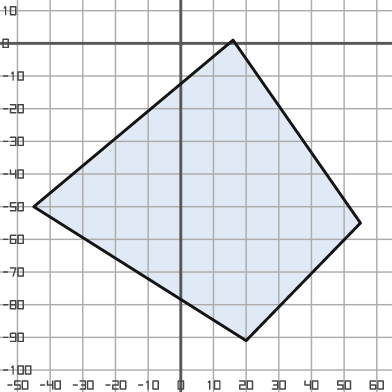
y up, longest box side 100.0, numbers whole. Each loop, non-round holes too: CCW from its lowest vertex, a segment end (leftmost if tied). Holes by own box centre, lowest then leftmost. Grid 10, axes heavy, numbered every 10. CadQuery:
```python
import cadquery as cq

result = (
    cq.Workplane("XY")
    .moveTo(20.0, -91.0)
    .lineTo(55.0, -55.0)
    .lineTo(16.0, 1.0)
    .lineTo(-45.0, -50.0)
    .close()
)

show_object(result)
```